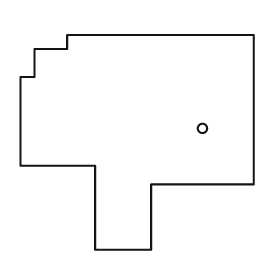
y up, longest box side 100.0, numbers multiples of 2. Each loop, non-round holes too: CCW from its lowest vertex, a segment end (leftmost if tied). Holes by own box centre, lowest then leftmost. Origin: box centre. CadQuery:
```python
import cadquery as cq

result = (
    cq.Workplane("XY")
    .moveTo(-18.0, -46.0)
    .lineTo(6.0, -46.0)
    .lineTo(6.0, -18.0)
    .lineTo(50.0, -18.0)
    .lineTo(50.0, 46.0)
    .lineTo(-30.0, 46.0)
    .lineTo(-30.0, 40.0)
    .lineTo(-44.0, 40.0)
    .lineTo(-44.0, 28.0)
    .lineTo(-50.0, 28.0)
    .lineTo(-50.0, -10.0)
    .lineTo(-18.0, -10.0)
    .close()
    .moveTo(28.0, 6.0)
    .circle(2.0)
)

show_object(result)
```